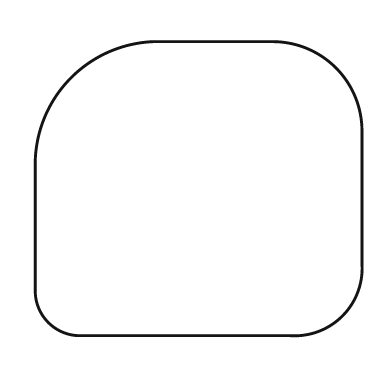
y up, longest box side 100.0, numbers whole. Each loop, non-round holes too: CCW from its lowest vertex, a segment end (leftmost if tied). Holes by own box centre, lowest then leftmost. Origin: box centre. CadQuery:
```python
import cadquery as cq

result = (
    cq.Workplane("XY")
    .moveTo(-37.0, -45.0)
    .lineTo(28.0, -45.0)
    .threePointArc((44.0, -39.0), (50.0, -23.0))
    .lineTo(50.0, 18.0)
    .threePointArc((42.0, 37.0), (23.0, 45.0))
    .lineTo(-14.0, 45.0)
    .threePointArc((-39.0, 34.0), (-50.0, 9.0))
    .lineTo(-50.0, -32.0)
    .threePointArc((-46.0, -41.0), (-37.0, -45.0))
    .close()
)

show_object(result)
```